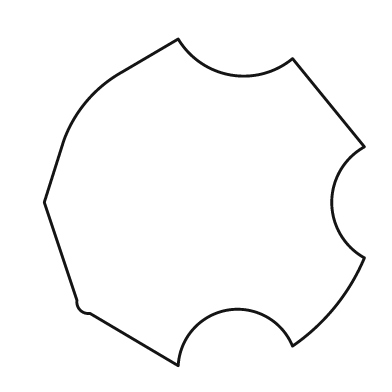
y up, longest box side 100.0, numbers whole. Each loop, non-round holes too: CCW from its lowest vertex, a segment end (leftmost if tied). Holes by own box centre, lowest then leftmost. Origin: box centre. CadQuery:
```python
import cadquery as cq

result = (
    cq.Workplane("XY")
    .moveTo(-8.0, -50.0)
    .threePointArc((7.0, -33.0), (27.0, -44.0))
    .threePointArc((40.0, -32.0), (49.0, -17.0))
    .threePointArc((39.0, 0.0), (49.0, 17.0))
    .lineTo(27.0, 44.0)
    .threePointArc((8.0, 39.0), (-8.0, 50.0))
    .lineTo(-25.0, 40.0)
    .threePointArc((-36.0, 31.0), (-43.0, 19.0))
    .lineTo(-49.0, 0.0)
    .lineTo(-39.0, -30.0)
    .threePointArc((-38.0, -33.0), (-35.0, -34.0))
    .close()
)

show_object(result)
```